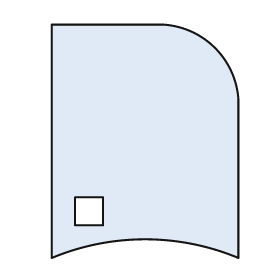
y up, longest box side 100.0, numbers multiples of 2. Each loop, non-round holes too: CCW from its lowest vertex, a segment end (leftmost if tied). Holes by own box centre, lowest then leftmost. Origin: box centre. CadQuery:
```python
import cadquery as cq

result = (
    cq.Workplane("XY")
    .moveTo(-40.0, -50.0)
    .threePointArc((0.0, -42.0), (40.0, -50.0))
    .lineTo(40.0, 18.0)
    .threePointArc((30.0, 40.0), (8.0, 50.0))
    .lineTo(-40.0, 50.0)
    .close()
    .moveTo(-30.0, -36.0)
    .lineTo(-18.0, -36.0)
    .lineTo(-18.0, -24.0)
    .lineTo(-30.0, -24.0)
    .close()
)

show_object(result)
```